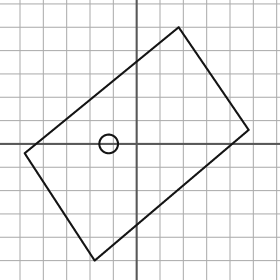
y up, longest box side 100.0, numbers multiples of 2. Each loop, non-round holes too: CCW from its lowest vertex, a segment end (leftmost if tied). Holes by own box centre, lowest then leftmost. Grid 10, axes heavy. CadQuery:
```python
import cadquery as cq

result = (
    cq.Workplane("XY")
    .moveTo(-18.0, -50.0)
    .lineTo(48.0, 6.0)
    .lineTo(18.0, 50.0)
    .lineTo(-48.0, -4.0)
    .close()
    .moveTo(-12.0, 0.0)
    .circle(4.0)
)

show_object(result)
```